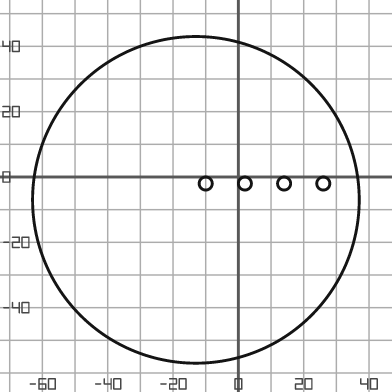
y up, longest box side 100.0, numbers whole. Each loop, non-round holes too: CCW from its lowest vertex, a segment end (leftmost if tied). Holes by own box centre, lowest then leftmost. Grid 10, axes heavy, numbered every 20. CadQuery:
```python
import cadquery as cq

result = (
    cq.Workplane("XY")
    .moveTo(-13.0, -7.0)
    .circle(50.0)
    .moveTo(-10.0, -2.0)
    .circle(2.0)
    .moveTo(2.0, -2.0)
    .circle(2.0)
    .moveTo(14.0, -2.0)
    .circle(2.0)
    .moveTo(26.0, -2.0)
    .circle(2.0)
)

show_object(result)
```